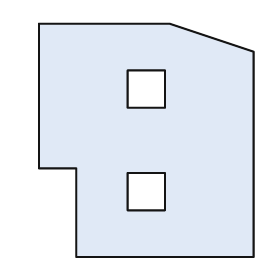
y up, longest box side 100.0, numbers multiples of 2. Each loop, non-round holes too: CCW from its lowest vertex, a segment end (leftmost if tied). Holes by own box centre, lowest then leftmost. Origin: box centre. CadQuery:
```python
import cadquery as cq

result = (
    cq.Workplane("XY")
    .moveTo(-30.0, -50.0)
    .lineTo(46.0, -50.0)
    .lineTo(46.0, 38.0)
    .lineTo(10.0, 50.0)
    .lineTo(-46.0, 50.0)
    .lineTo(-46.0, -12.0)
    .lineTo(-30.0, -12.0)
    .close()
    .moveTo(-8.0, -30.0)
    .lineTo(8.0, -30.0)
    .lineTo(8.0, -14.0)
    .lineTo(-8.0, -14.0)
    .close()
    .moveTo(-8.0, 14.0)
    .lineTo(8.0, 14.0)
    .lineTo(8.0, 30.0)
    .lineTo(-8.0, 30.0)
    .close()
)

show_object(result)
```